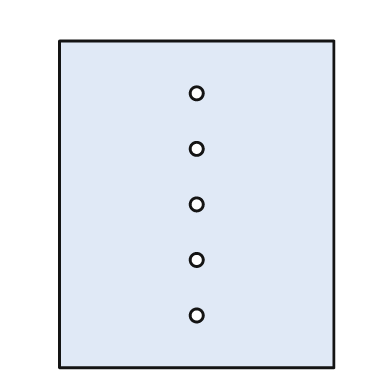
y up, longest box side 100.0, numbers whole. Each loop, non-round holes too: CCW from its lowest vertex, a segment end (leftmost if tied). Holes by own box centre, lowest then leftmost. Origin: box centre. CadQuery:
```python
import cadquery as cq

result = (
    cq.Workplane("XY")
    .moveTo(-42.0, -50.0)
    .lineTo(42.0, -50.0)
    .lineTo(42.0, 50.0)
    .lineTo(-42.0, 50.0)
    .close()
    .moveTo(0.0, -34.0)
    .circle(2.0)
    .moveTo(0.0, -17.0)
    .circle(2.0)
    .moveTo(0.0, 0.0)
    .circle(2.0)
    .moveTo(0.0, 17.0)
    .circle(2.0)
    .moveTo(0.0, 34.0)
    .circle(2.0)
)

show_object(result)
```